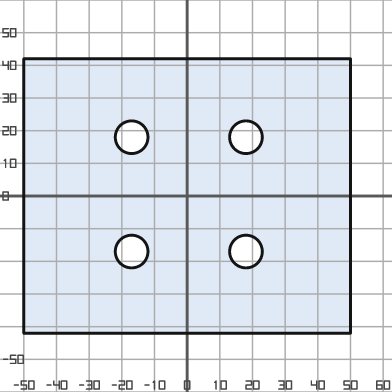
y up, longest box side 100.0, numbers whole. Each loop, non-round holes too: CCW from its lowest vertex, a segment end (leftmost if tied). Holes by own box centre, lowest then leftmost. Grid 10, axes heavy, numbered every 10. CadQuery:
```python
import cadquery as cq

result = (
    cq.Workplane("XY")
    .moveTo(-50.0, -42.0)
    .lineTo(50.0, -42.0)
    .lineTo(50.0, 42.0)
    .lineTo(-50.0, 42.0)
    .close()
    .moveTo(-17.0, -17.0)
    .circle(5.0)
    .moveTo(18.0, -17.0)
    .circle(5.0)
    .moveTo(-17.0, 18.0)
    .circle(5.0)
    .moveTo(18.0, 18.0)
    .circle(5.0)
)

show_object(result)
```